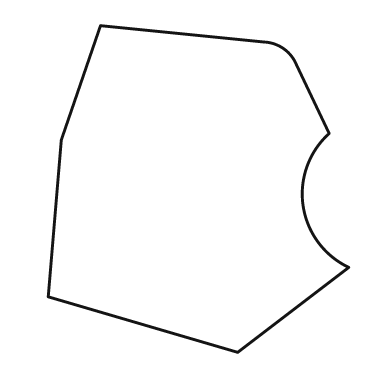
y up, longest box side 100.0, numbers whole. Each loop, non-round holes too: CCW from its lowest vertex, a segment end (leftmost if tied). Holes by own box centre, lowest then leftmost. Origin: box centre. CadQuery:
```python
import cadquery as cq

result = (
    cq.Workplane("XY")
    .moveTo(12.0, -50.0)
    .lineTo(46.0, -24.0)
    .threePointArc((32.0, -5.0), (40.0, 17.0))
    .lineTo(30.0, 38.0)
    .threePointArc((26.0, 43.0), (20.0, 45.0))
    .lineTo(-30.0, 50.0)
    .lineTo(-42.0, 15.0)
    .lineTo(-46.0, -33.0)
    .close()
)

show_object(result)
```